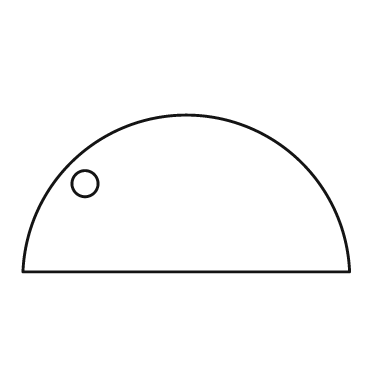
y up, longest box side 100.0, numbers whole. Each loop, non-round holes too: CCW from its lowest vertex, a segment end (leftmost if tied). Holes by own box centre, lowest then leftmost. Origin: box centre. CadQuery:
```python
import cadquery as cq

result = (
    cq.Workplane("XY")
    .moveTo(-50.0, -24.0)
    .lineTo(50.0, -24.0)
    .threePointArc((0.0, 24.0), (-50.0, -24.0))
    .close()
    .moveTo(-31.0, 3.0)
    .circle(4.0)
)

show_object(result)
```